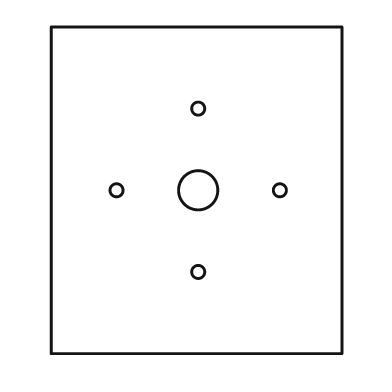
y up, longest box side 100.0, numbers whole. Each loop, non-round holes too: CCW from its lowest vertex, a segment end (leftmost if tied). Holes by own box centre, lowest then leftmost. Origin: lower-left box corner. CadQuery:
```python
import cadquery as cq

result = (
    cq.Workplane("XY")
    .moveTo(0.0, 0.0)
    .lineTo(89.0, 0.0)
    .lineTo(89.0, 100.0)
    .lineTo(0.0, 100.0)
    .close()
    .moveTo(45.0, 25.0)
    .circle(2.0)
    .moveTo(20.0, 50.0)
    .circle(2.0)
    .moveTo(45.0, 50.0)
    .circle(6.0)
    .moveTo(70.0, 50.0)
    .circle(2.0)
    .moveTo(45.0, 75.0)
    .circle(2.0)
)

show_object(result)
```